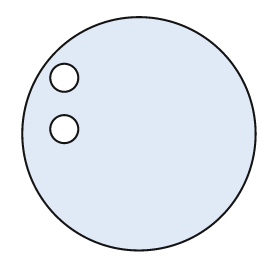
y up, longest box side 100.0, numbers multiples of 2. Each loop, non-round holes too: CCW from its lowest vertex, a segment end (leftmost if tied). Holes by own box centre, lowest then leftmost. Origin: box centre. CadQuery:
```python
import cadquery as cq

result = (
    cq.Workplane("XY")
    .moveTo(0.0, 0.0)
    .circle(50.0)
    .moveTo(-32.0, 2.0)
    .circle(6.0)
    .moveTo(-32.0, 24.0)
    .circle(6.0)
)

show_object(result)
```